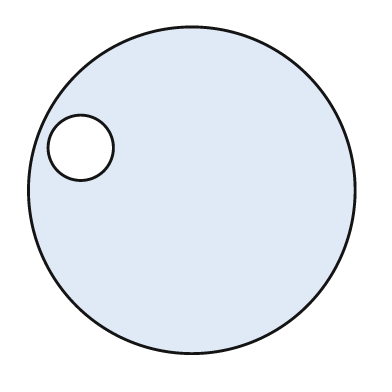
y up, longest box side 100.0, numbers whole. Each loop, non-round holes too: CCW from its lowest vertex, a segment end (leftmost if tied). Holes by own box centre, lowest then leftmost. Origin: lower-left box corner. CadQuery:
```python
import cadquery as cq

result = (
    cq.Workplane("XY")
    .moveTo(50.0, 50.0)
    .circle(50.0)
    .moveTo(16.0, 63.0)
    .circle(10.0)
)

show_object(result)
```